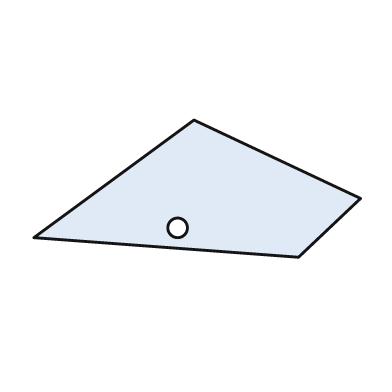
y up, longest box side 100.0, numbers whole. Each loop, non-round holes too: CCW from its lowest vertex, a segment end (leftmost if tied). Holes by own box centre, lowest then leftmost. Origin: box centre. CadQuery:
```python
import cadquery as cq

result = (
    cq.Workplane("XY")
    .moveTo(31.0, -21.0)
    .lineTo(50.0, -3.0)
    .lineTo(-1.0, 21.0)
    .lineTo(-50.0, -15.0)
    .close()
    .moveTo(-6.0, -12.0)
    .circle(3.0)
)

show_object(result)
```